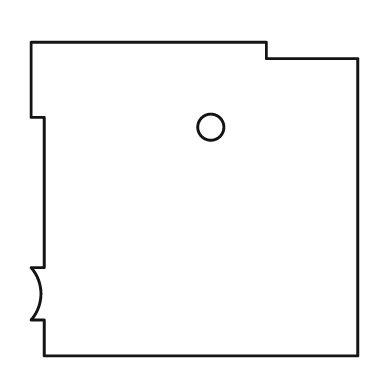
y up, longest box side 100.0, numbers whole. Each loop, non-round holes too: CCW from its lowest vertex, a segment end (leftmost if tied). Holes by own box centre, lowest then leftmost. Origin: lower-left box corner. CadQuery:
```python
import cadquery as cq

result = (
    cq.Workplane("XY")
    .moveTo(4.0, 0.0)
    .lineTo(100.0, 0.0)
    .lineTo(100.0, 91.0)
    .lineTo(72.0, 91.0)
    .lineTo(72.0, 96.0)
    .lineTo(0.0, 96.0)
    .lineTo(0.0, 73.0)
    .lineTo(4.0, 73.0)
    .lineTo(4.0, 27.0)
    .lineTo(0.0, 27.0)
    .threePointArc((3.0, 19.0), (0.0, 11.0))
    .lineTo(4.0, 11.0)
    .close()
    .moveTo(55.0, 70.0)
    .circle(4.0)
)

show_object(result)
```